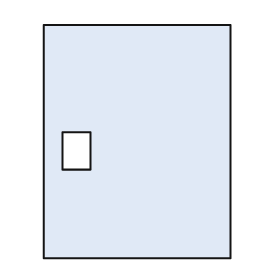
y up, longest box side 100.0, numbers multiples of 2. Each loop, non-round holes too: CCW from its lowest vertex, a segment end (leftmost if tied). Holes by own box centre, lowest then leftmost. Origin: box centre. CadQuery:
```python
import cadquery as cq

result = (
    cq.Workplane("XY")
    .moveTo(-40.0, -50.0)
    .lineTo(40.0, -50.0)
    .lineTo(40.0, 50.0)
    .lineTo(-40.0, 50.0)
    .close()
    .moveTo(-32.0, -12.0)
    .lineTo(-20.0, -12.0)
    .lineTo(-20.0, 4.0)
    .lineTo(-32.0, 4.0)
    .close()
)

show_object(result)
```